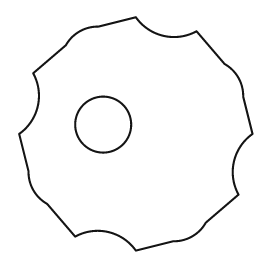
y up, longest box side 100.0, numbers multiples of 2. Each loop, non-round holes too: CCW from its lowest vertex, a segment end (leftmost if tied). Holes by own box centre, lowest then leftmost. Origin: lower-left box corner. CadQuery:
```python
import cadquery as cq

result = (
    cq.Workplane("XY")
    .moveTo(50.0, 0.0)
    .lineTo(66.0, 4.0)
    .threePointArc((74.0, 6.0), (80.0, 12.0))
    .lineTo(94.0, 24.0)
    .threePointArc((92.0, 38.0), (100.0, 50.0))
    .lineTo(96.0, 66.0)
    .threePointArc((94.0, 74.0), (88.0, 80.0))
    .lineTo(76.0, 94.0)
    .threePointArc((62.0, 92.0), (50.0, 100.0))
    .lineTo(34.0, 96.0)
    .threePointArc((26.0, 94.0), (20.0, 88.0))
    .lineTo(6.0, 76.0)
    .threePointArc((8.0, 62.0), (0.0, 50.0))
    .lineTo(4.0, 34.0)
    .threePointArc((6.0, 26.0), (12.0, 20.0))
    .lineTo(24.0, 6.0)
    .threePointArc((38.0, 8.0), (50.0, 0.0))
    .close()
    .moveTo(36.0, 54.0)
    .circle(12.0)
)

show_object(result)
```